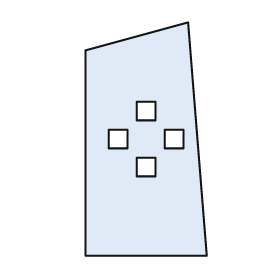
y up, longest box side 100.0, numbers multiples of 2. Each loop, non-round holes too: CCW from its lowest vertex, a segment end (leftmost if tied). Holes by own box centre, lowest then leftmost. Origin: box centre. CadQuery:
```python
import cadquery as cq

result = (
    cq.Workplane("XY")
    .moveTo(-26.0, -50.0)
    .lineTo(26.0, -50.0)
    .lineTo(18.0, 50.0)
    .lineTo(-26.0, 38.0)
    .close()
    .moveTo(-4.0, -16.0)
    .lineTo(4.0, -16.0)
    .lineTo(4.0, -8.0)
    .lineTo(-4.0, -8.0)
    .close()
    .moveTo(-16.0, -4.0)
    .lineTo(-8.0, -4.0)
    .lineTo(-8.0, 4.0)
    .lineTo(-16.0, 4.0)
    .close()
    .moveTo(8.0, -4.0)
    .lineTo(16.0, -4.0)
    .lineTo(16.0, 4.0)
    .lineTo(8.0, 4.0)
    .close()
    .moveTo(-4.0, 8.0)
    .lineTo(4.0, 8.0)
    .lineTo(4.0, 16.0)
    .lineTo(-4.0, 16.0)
    .close()
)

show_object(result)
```